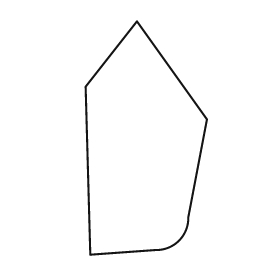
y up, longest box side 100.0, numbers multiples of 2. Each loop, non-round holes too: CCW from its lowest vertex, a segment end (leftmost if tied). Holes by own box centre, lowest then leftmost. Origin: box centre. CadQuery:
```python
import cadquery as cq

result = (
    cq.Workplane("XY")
    .moveTo(-24.0, -50.0)
    .lineTo(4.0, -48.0)
    .threePointArc((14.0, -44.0), (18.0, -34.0))
    .lineTo(26.0, 8.0)
    .lineTo(-4.0, 50.0)
    .lineTo(-26.0, 22.0)
    .close()
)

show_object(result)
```